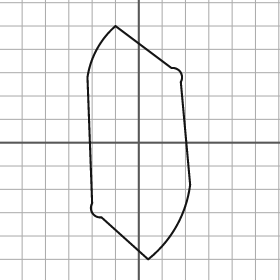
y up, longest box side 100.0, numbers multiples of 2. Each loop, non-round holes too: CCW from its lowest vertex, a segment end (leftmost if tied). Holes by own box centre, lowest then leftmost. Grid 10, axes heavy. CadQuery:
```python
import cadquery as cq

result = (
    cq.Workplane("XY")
    .moveTo(4.0, -50.0)
    .threePointArc((16.0, -36.0), (22.0, -18.0))
    .lineTo(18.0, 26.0)
    .threePointArc((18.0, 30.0), (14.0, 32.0))
    .lineTo(-10.0, 50.0)
    .threePointArc((-18.0, 40.0), (-22.0, 28.0))
    .lineTo(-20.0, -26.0)
    .threePointArc((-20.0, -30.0), (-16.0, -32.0))
    .close()
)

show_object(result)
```